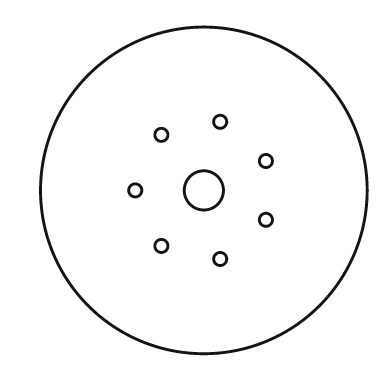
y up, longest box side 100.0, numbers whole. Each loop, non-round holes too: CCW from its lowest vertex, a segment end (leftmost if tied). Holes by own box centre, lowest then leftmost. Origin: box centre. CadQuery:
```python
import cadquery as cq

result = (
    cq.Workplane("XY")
    .moveTo(0.0, 0.0)
    .circle(50.0)
    .moveTo(5.0, -21.0)
    .circle(2.0)
    .moveTo(-13.0, -17.0)
    .circle(2.0)
    .moveTo(19.0, -9.0)
    .circle(2.0)
    .moveTo(-21.0, 0.0)
    .circle(2.0)
    .moveTo(0.0, 0.0)
    .circle(6.0)
    .moveTo(19.0, 9.0)
    .circle(2.0)
    .moveTo(-13.0, 17.0)
    .circle(2.0)
    .moveTo(5.0, 21.0)
    .circle(2.0)
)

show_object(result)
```